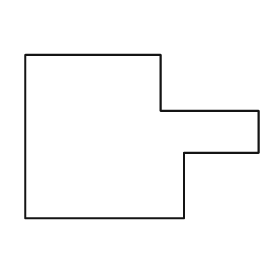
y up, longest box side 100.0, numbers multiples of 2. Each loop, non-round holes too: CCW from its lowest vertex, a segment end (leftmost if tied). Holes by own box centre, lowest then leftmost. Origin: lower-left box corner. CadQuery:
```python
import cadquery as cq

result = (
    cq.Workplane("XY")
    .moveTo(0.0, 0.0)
    .lineTo(68.0, 0.0)
    .lineTo(68.0, 28.0)
    .lineTo(100.0, 28.0)
    .lineTo(100.0, 46.0)
    .lineTo(58.0, 46.0)
    .lineTo(58.0, 70.0)
    .lineTo(0.0, 70.0)
    .close()
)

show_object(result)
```